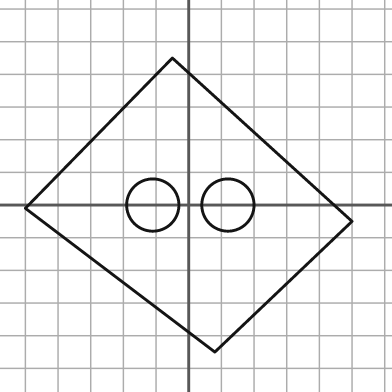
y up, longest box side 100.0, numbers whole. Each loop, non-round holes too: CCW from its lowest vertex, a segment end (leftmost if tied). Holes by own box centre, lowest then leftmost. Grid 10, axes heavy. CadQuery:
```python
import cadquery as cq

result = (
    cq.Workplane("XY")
    .moveTo(8.0, -45.0)
    .lineTo(50.0, -5.0)
    .lineTo(-5.0, 45.0)
    .lineTo(-50.0, -1.0)
    .close()
    .moveTo(-11.0, 0.0)
    .circle(8.0)
    .moveTo(12.0, 0.0)
    .circle(8.0)
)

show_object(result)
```